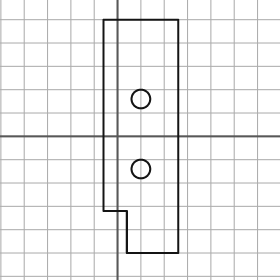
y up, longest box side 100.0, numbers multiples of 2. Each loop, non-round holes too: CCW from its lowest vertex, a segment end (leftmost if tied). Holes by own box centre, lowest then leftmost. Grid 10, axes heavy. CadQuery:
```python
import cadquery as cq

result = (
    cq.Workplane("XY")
    .moveTo(4.0, -50.0)
    .lineTo(26.0, -50.0)
    .lineTo(26.0, 50.0)
    .lineTo(-6.0, 50.0)
    .lineTo(-6.0, -32.0)
    .lineTo(4.0, -32.0)
    .close()
    .moveTo(10.0, -14.0)
    .circle(4.0)
    .moveTo(10.0, 16.0)
    .circle(4.0)
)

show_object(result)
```